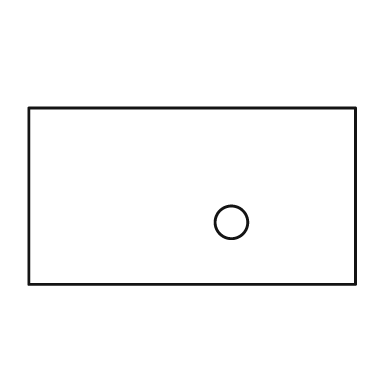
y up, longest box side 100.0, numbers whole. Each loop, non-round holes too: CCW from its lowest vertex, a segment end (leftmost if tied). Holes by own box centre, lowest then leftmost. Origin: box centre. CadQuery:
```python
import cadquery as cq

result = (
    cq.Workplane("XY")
    .moveTo(-50.0, -27.0)
    .lineTo(50.0, -27.0)
    .lineTo(50.0, 27.0)
    .lineTo(-50.0, 27.0)
    .close()
    .moveTo(12.0, -8.0)
    .circle(5.0)
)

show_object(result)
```